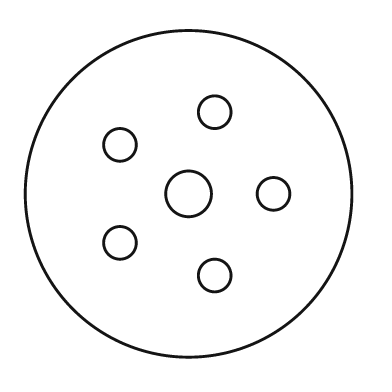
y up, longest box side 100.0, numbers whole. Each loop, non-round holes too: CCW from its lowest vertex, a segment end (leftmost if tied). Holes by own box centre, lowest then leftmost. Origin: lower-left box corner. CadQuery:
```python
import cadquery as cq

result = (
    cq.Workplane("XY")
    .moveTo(50.0, 50.0)
    .circle(50.0)
    .moveTo(58.0, 25.0)
    .circle(5.0)
    .moveTo(29.0, 35.0)
    .circle(5.0)
    .moveTo(50.0, 50.0)
    .circle(7.0)
    .moveTo(76.0, 50.0)
    .circle(5.0)
    .moveTo(29.0, 65.0)
    .circle(5.0)
    .moveTo(58.0, 75.0)
    .circle(5.0)
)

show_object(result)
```